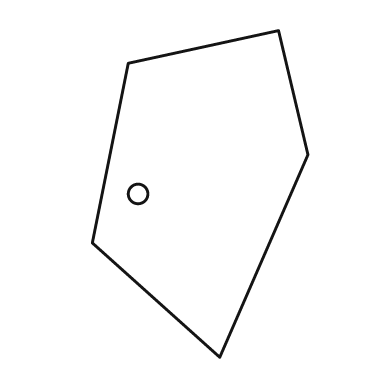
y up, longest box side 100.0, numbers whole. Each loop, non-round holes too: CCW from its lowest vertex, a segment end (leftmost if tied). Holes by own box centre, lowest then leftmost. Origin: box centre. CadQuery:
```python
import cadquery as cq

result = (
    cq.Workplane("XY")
    .moveTo(6.0, -50.0)
    .lineTo(33.0, 12.0)
    .lineTo(24.0, 50.0)
    .lineTo(-22.0, 40.0)
    .lineTo(-33.0, -15.0)
    .close()
    .moveTo(-19.0, 0.0)
    .circle(3.0)
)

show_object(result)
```